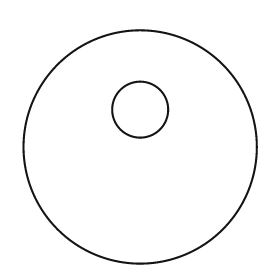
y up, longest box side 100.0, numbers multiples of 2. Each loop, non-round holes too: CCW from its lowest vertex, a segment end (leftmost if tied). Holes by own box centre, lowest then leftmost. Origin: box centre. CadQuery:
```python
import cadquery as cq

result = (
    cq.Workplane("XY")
    .moveTo(0.0, 0.0)
    .circle(50.0)
    .moveTo(0.0, 16.0)
    .circle(12.0)
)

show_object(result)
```